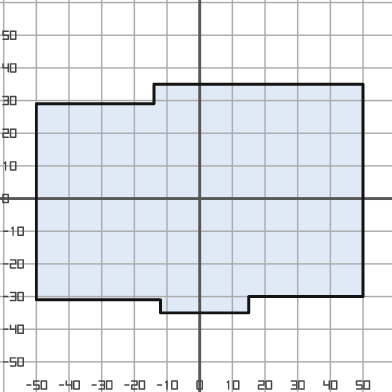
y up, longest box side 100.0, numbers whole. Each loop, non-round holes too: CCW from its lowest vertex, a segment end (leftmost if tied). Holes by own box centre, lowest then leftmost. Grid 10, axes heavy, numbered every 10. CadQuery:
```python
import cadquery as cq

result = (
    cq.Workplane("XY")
    .moveTo(-12.0, -35.0)
    .lineTo(15.0, -35.0)
    .lineTo(15.0, -30.0)
    .lineTo(50.0, -30.0)
    .lineTo(50.0, 35.0)
    .lineTo(-14.0, 35.0)
    .lineTo(-14.0, 29.0)
    .lineTo(-50.0, 29.0)
    .lineTo(-50.0, -31.0)
    .lineTo(-12.0, -31.0)
    .close()
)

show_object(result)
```